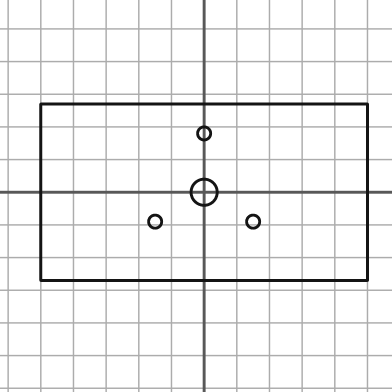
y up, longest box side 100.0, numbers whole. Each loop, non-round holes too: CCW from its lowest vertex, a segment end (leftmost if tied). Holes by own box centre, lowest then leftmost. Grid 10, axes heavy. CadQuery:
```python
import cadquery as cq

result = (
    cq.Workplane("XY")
    .moveTo(-50.0, -27.0)
    .lineTo(50.0, -27.0)
    .lineTo(50.0, 27.0)
    .lineTo(-50.0, 27.0)
    .close()
    .moveTo(-15.0, -9.0)
    .circle(2.0)
    .moveTo(15.0, -9.0)
    .circle(2.0)
    .moveTo(0.0, 0.0)
    .circle(4.0)
    .moveTo(0.0, 18.0)
    .circle(2.0)
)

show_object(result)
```